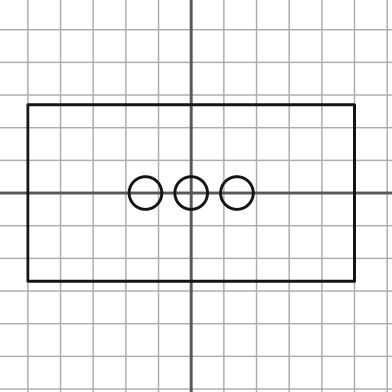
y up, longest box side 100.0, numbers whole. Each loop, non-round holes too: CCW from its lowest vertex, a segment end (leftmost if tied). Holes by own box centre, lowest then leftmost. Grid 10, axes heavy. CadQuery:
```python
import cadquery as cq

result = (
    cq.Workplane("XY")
    .moveTo(-50.0, -27.0)
    .lineTo(50.0, -27.0)
    .lineTo(50.0, 27.0)
    .lineTo(-50.0, 27.0)
    .close()
    .moveTo(-14.0, 0.0)
    .circle(5.0)
    .moveTo(0.0, 0.0)
    .circle(5.0)
    .moveTo(14.0, 0.0)
    .circle(5.0)
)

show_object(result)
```